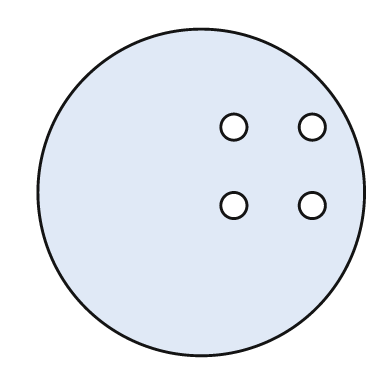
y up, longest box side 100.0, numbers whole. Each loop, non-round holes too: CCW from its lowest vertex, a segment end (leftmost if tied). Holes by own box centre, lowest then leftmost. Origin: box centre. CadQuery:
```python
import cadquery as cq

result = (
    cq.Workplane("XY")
    .moveTo(0.0, 0.0)
    .circle(50.0)
    .moveTo(10.0, -4.0)
    .circle(4.0)
    .moveTo(34.0, -4.0)
    .circle(4.0)
    .moveTo(10.0, 20.0)
    .circle(4.0)
    .moveTo(34.0, 20.0)
    .circle(4.0)
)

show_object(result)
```